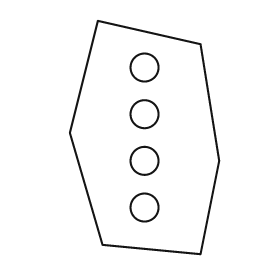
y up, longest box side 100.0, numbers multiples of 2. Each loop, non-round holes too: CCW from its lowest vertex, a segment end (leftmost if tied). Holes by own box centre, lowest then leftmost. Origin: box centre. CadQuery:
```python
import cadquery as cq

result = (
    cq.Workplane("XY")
    .moveTo(24.0, -50.0)
    .lineTo(32.0, -10.0)
    .lineTo(24.0, 40.0)
    .lineTo(-20.0, 50.0)
    .lineTo(-32.0, 2.0)
    .lineTo(-18.0, -46.0)
    .close()
    .moveTo(0.0, -30.0)
    .circle(6.0)
    .moveTo(0.0, -10.0)
    .circle(6.0)
    .moveTo(0.0, 10.0)
    .circle(6.0)
    .moveTo(0.0, 30.0)
    .circle(6.0)
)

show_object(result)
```